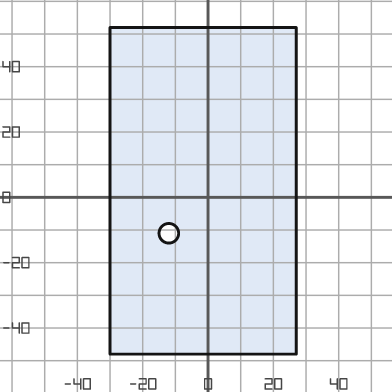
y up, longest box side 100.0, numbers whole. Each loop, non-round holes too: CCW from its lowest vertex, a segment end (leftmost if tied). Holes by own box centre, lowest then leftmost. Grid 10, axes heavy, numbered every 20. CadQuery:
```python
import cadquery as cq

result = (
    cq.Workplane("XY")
    .moveTo(-30.0, -48.0)
    .lineTo(27.0, -48.0)
    .lineTo(27.0, 52.0)
    .lineTo(-30.0, 52.0)
    .close()
    .moveTo(-12.0, -11.0)
    .circle(3.0)
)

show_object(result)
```